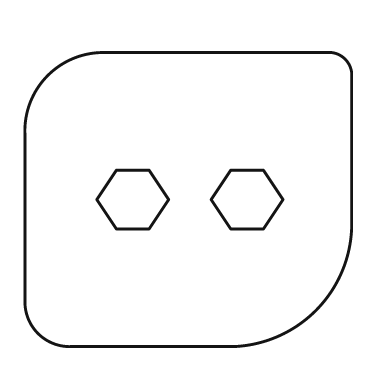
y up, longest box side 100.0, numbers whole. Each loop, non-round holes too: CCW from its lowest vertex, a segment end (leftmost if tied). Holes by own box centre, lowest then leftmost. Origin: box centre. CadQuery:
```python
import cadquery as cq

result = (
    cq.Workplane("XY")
    .moveTo(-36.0, -45.0)
    .lineTo(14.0, -45.0)
    .threePointArc((39.0, -34.0), (50.0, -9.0))
    .lineTo(50.0, 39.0)
    .threePointArc((48.0, 43.0), (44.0, 45.0))
    .lineTo(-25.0, 45.0)
    .threePointArc((-43.0, 38.0), (-50.0, 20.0))
    .lineTo(-50.0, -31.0)
    .threePointArc((-46.0, -41.0), (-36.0, -45.0))
    .close()
    .moveTo(-22.0, -9.0)
    .lineTo(-12.0, -9.0)
    .lineTo(-6.0, 0.0)
    .lineTo(-12.0, 9.0)
    .lineTo(-22.0, 9.0)
    .lineTo(-28.0, 0.0)
    .close()
    .moveTo(13.0, -9.0)
    .lineTo(23.0, -9.0)
    .lineTo(29.0, 0.0)
    .lineTo(23.0, 9.0)
    .lineTo(13.0, 9.0)
    .lineTo(7.0, 0.0)
    .close()
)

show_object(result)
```